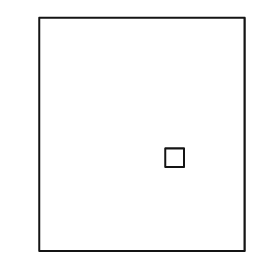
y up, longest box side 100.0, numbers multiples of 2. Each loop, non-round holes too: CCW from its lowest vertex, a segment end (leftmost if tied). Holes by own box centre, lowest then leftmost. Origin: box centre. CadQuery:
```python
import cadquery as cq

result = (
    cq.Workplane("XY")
    .moveTo(-44.0, -50.0)
    .lineTo(44.0, -50.0)
    .lineTo(44.0, 50.0)
    .lineTo(-44.0, 50.0)
    .close()
    .moveTo(10.0, -14.0)
    .lineTo(18.0, -14.0)
    .lineTo(18.0, -6.0)
    .lineTo(10.0, -6.0)
    .close()
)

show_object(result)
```